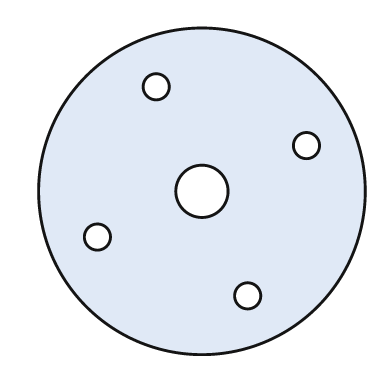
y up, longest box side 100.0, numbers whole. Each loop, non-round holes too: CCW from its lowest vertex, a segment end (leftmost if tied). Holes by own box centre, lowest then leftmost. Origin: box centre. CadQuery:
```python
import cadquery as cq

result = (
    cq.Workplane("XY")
    .moveTo(0.0, 0.0)
    .circle(50.0)
    .moveTo(14.0, -32.0)
    .circle(4.0)
    .moveTo(-32.0, -14.0)
    .circle(4.0)
    .moveTo(0.0, 0.0)
    .circle(8.0)
    .moveTo(32.0, 14.0)
    .circle(4.0)
    .moveTo(-14.0, 32.0)
    .circle(4.0)
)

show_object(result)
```